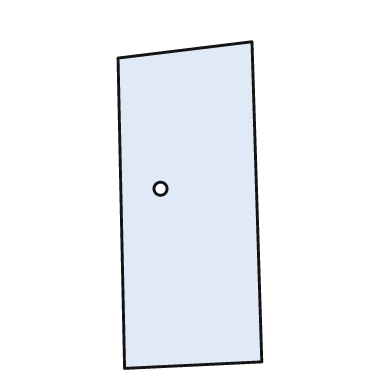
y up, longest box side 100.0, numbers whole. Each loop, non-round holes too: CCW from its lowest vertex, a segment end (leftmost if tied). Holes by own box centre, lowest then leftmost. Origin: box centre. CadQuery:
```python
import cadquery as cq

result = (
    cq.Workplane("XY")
    .moveTo(-20.0, -50.0)
    .lineTo(22.0, -48.0)
    .lineTo(19.0, 50.0)
    .lineTo(-22.0, 45.0)
    .close()
    .moveTo(-9.0, 5.0)
    .circle(2.0)
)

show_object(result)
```